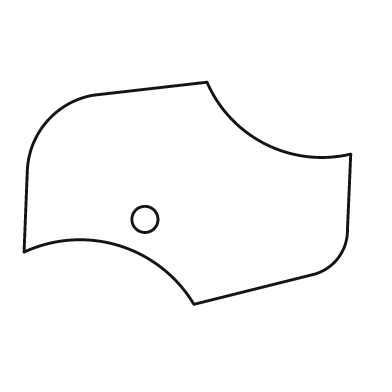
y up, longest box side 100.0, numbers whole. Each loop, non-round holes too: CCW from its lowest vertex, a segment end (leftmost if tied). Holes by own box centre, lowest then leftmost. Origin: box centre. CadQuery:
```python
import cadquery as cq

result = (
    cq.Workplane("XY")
    .moveTo(2.0, -34.0)
    .lineTo(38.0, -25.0)
    .threePointArc((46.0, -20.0), (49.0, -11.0))
    .lineTo(50.0, 12.0)
    .threePointArc((24.0, 15.0), (6.0, 34.0))
    .lineTo(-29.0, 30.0)
    .threePointArc((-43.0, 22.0), (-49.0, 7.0))
    .lineTo(-50.0, -18.0)
    .threePointArc((-21.0, -16.0), (2.0, -34.0))
    .close()
    .moveTo(-13.0, -8.0)
    .circle(4.0)
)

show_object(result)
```